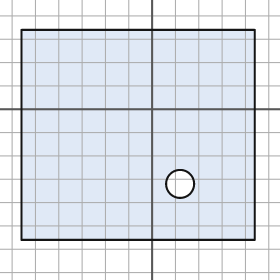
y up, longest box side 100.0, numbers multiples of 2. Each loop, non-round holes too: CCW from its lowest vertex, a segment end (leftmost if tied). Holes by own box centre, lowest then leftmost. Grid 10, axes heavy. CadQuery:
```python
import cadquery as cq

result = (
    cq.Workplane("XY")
    .moveTo(-56.0, -56.0)
    .lineTo(44.0, -56.0)
    .lineTo(44.0, 34.0)
    .lineTo(-56.0, 34.0)
    .close()
    .moveTo(12.0, -32.0)
    .circle(6.0)
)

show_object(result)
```